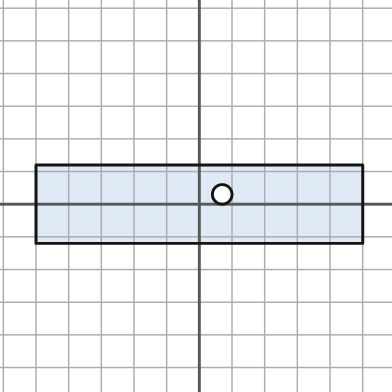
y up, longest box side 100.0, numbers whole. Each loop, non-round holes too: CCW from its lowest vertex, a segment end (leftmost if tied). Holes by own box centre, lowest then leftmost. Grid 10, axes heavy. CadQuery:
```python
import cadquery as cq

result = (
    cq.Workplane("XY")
    .moveTo(-50.0, -12.0)
    .lineTo(50.0, -12.0)
    .lineTo(50.0, 12.0)
    .lineTo(-50.0, 12.0)
    .close()
    .moveTo(7.0, 3.0)
    .circle(3.0)
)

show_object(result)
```